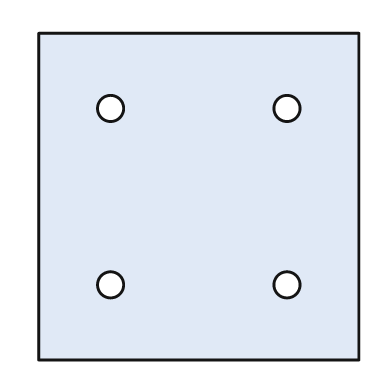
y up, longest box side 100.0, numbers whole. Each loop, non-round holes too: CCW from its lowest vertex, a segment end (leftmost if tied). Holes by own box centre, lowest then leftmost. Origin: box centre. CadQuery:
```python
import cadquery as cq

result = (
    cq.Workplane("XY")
    .moveTo(-49.0, -50.0)
    .lineTo(49.0, -50.0)
    .lineTo(49.0, 50.0)
    .lineTo(-49.0, 50.0)
    .close()
    .moveTo(-27.0, -27.0)
    .circle(4.0)
    .moveTo(27.0, -27.0)
    .circle(4.0)
    .moveTo(-27.0, 27.0)
    .circle(4.0)
    .moveTo(27.0, 27.0)
    .circle(4.0)
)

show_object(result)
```